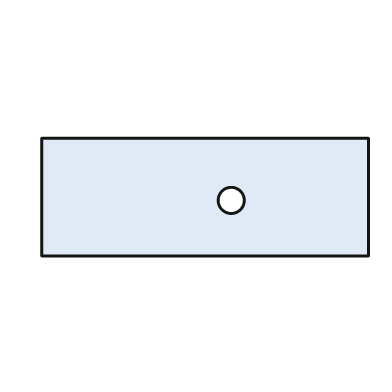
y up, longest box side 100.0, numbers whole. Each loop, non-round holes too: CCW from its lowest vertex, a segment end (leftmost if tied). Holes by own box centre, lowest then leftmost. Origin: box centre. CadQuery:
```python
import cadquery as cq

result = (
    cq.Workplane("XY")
    .moveTo(-50.0, -18.0)
    .lineTo(50.0, -18.0)
    .lineTo(50.0, 18.0)
    .lineTo(-50.0, 18.0)
    .close()
    .moveTo(8.0, -1.0)
    .circle(4.0)
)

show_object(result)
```